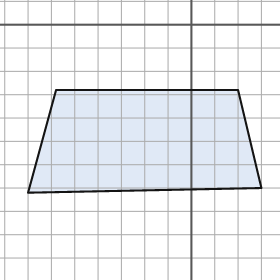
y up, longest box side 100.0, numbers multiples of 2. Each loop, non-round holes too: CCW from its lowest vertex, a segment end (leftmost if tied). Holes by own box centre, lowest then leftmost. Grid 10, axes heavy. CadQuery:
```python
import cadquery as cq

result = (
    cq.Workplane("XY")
    .moveTo(-70.0, -72.0)
    .lineTo(30.0, -70.0)
    .lineTo(20.0, -28.0)
    .lineTo(-58.0, -28.0)
    .close()
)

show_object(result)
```